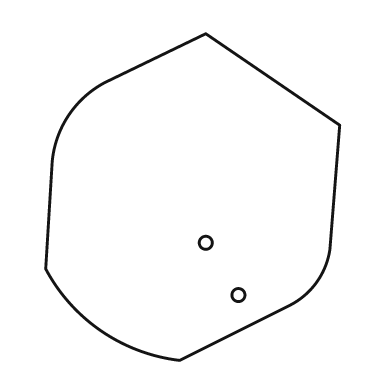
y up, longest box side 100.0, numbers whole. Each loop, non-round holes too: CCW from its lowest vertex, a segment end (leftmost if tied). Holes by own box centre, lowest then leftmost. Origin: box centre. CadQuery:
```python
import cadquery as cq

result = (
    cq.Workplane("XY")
    .moveTo(-4.0, -50.0)
    .lineTo(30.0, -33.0)
    .threePointArc((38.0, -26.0), (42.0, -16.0))
    .lineTo(45.0, 22.0)
    .lineTo(4.0, 50.0)
    .lineTo(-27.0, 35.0)
    .threePointArc((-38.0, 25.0), (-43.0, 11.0))
    .lineTo(-45.0, -22.0)
    .threePointArc((-28.0, -41.0), (-4.0, -50.0))
    .close()
    .moveTo(14.0, -30.0)
    .circle(2.0)
    .moveTo(4.0, -14.0)
    .circle(2.0)
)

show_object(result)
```